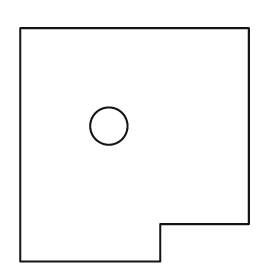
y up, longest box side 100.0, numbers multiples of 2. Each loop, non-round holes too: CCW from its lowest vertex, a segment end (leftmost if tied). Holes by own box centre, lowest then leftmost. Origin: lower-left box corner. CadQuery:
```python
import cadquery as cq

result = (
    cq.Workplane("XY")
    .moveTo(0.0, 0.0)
    .lineTo(60.0, 0.0)
    .lineTo(60.0, 16.0)
    .lineTo(98.0, 16.0)
    .lineTo(98.0, 100.0)
    .lineTo(0.0, 100.0)
    .close()
    .moveTo(38.0, 58.0)
    .circle(8.0)
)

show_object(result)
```